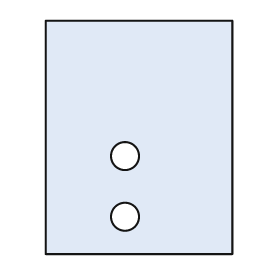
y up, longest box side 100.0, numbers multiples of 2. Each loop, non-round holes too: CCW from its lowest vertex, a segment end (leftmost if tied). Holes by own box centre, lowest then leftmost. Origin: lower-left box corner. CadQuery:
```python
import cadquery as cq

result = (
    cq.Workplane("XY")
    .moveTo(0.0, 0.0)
    .lineTo(80.0, 0.0)
    .lineTo(80.0, 100.0)
    .lineTo(0.0, 100.0)
    .close()
    .moveTo(34.0, 16.0)
    .circle(6.0)
    .moveTo(34.0, 42.0)
    .circle(6.0)
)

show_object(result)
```